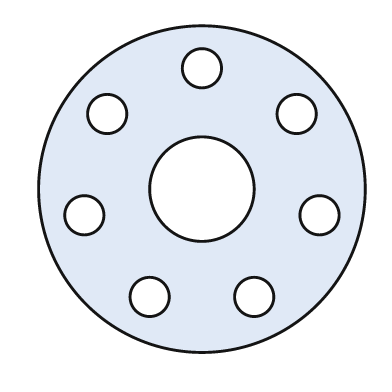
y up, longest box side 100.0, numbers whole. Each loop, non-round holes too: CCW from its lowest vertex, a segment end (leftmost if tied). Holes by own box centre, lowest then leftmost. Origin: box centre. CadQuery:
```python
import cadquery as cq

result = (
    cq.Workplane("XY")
    .moveTo(0.0, 0.0)
    .circle(50.0)
    .moveTo(-16.0, -33.0)
    .circle(6.0)
    .moveTo(16.0, -33.0)
    .circle(6.0)
    .moveTo(-36.0, -8.0)
    .circle(6.0)
    .moveTo(36.0, -8.0)
    .circle(6.0)
    .moveTo(0.0, 0.0)
    .circle(16.0)
    .moveTo(-29.0, 23.0)
    .circle(6.0)
    .moveTo(29.0, 23.0)
    .circle(6.0)
    .moveTo(0.0, 37.0)
    .circle(6.0)
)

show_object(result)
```